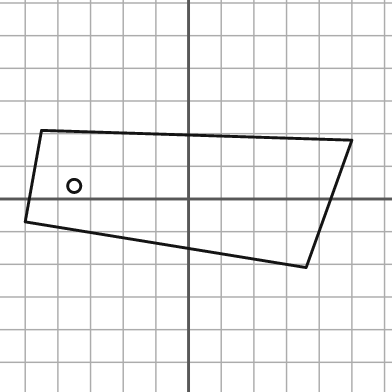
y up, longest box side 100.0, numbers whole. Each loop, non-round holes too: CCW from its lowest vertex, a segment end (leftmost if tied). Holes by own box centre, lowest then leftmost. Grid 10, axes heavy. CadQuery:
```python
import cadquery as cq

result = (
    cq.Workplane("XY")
    .moveTo(36.0, -21.0)
    .lineTo(50.0, 18.0)
    .lineTo(-45.0, 21.0)
    .lineTo(-50.0, -7.0)
    .close()
    .moveTo(-35.0, 4.0)
    .circle(2.0)
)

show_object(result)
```